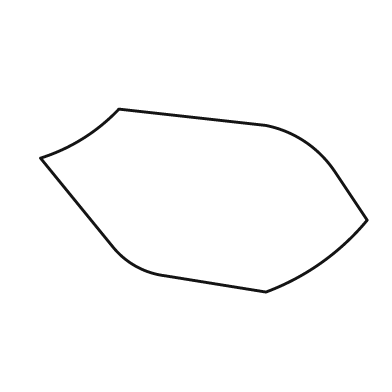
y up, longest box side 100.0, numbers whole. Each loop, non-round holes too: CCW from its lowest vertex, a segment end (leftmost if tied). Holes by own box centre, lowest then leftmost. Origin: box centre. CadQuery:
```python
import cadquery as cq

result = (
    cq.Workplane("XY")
    .moveTo(19.0, -28.0)
    .threePointArc((36.0, -19.0), (50.0, -6.0))
    .lineTo(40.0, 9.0)
    .threePointArc((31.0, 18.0), (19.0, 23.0))
    .lineTo(-26.0, 28.0)
    .threePointArc((-37.0, 19.0), (-50.0, 13.0))
    .lineTo(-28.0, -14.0)
    .threePointArc((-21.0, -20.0), (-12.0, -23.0))
    .close()
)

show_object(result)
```